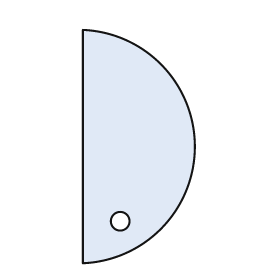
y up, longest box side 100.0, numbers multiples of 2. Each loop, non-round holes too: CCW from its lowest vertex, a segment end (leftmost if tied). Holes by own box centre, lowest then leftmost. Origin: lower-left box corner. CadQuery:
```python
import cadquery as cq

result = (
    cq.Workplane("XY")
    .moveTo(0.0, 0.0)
    .threePointArc((48.0, 50.0), (0.0, 100.0))
    .close()
    .moveTo(16.0, 18.0)
    .circle(4.0)
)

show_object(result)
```